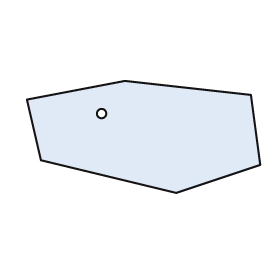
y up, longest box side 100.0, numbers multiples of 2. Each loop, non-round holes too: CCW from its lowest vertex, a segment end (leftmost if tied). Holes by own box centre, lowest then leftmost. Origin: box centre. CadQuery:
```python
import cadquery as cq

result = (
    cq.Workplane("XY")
    .moveTo(14.0, -24.0)
    .lineTo(50.0, -12.0)
    .lineTo(46.0, 18.0)
    .lineTo(-8.0, 24.0)
    .lineTo(-50.0, 16.0)
    .lineTo(-44.0, -10.0)
    .close()
    .moveTo(-18.0, 10.0)
    .circle(2.0)
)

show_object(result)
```